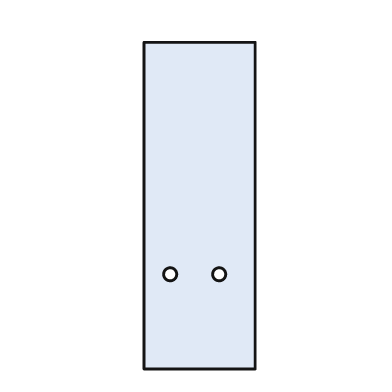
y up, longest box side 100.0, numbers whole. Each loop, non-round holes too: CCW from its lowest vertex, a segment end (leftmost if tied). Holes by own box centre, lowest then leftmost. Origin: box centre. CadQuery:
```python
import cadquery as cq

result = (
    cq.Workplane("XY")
    .moveTo(-17.0, -50.0)
    .lineTo(17.0, -50.0)
    .lineTo(17.0, 50.0)
    .lineTo(-17.0, 50.0)
    .close()
    .moveTo(-9.0, -21.0)
    .circle(2.0)
    .moveTo(6.0, -21.0)
    .circle(2.0)
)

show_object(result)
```